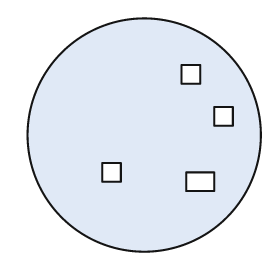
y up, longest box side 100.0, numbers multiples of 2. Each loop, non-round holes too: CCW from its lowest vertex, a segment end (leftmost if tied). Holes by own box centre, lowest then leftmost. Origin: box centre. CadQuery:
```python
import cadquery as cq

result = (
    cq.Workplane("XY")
    .moveTo(0.0, 0.0)
    .circle(50.0)
    .moveTo(18.0, -24.0)
    .lineTo(30.0, -24.0)
    .lineTo(30.0, -16.0)
    .lineTo(18.0, -16.0)
    .close()
    .moveTo(-18.0, -20.0)
    .lineTo(-10.0, -20.0)
    .lineTo(-10.0, -12.0)
    .lineTo(-18.0, -12.0)
    .close()
    .moveTo(30.0, 4.0)
    .lineTo(38.0, 4.0)
    .lineTo(38.0, 12.0)
    .lineTo(30.0, 12.0)
    .close()
    .moveTo(16.0, 22.0)
    .lineTo(24.0, 22.0)
    .lineTo(24.0, 30.0)
    .lineTo(16.0, 30.0)
    .close()
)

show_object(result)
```